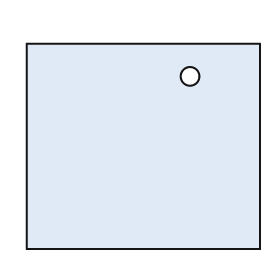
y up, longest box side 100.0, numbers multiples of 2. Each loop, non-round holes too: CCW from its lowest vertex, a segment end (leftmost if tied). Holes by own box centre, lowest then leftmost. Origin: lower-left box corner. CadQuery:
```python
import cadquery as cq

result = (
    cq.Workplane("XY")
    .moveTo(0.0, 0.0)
    .lineTo(100.0, 0.0)
    .lineTo(100.0, 88.0)
    .lineTo(0.0, 88.0)
    .close()
    .moveTo(70.0, 74.0)
    .circle(4.0)
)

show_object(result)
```